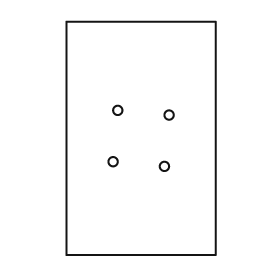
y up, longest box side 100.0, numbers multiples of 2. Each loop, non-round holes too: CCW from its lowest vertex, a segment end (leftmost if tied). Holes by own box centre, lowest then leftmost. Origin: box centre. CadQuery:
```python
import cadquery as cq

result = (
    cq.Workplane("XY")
    .moveTo(-32.0, -50.0)
    .lineTo(32.0, -50.0)
    .lineTo(32.0, 50.0)
    .lineTo(-32.0, 50.0)
    .close()
    .moveTo(10.0, -12.0)
    .circle(2.0)
    .moveTo(-12.0, -10.0)
    .circle(2.0)
    .moveTo(12.0, 10.0)
    .circle(2.0)
    .moveTo(-10.0, 12.0)
    .circle(2.0)
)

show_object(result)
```